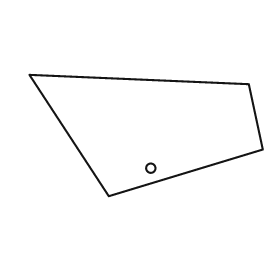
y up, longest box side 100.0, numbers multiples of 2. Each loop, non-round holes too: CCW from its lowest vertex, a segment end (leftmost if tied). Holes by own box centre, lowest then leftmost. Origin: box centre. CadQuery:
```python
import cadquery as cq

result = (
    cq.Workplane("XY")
    .moveTo(-16.0, -26.0)
    .lineTo(50.0, -6.0)
    .lineTo(44.0, 22.0)
    .lineTo(-50.0, 26.0)
    .close()
    .moveTo(2.0, -14.0)
    .circle(2.0)
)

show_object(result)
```